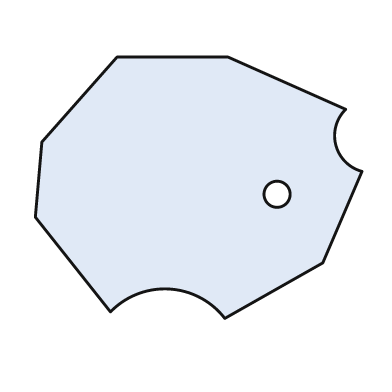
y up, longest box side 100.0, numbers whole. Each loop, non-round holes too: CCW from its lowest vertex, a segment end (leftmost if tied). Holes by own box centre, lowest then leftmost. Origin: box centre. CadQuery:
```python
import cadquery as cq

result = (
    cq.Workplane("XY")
    .moveTo(8.0, -40.0)
    .lineTo(38.0, -23.0)
    .lineTo(50.0, 5.0)
    .threePointArc((42.0, 13.0), (45.0, 24.0))
    .lineTo(9.0, 40.0)
    .lineTo(-25.0, 40.0)
    .lineTo(-48.0, 14.0)
    .lineTo(-50.0, -9.0)
    .lineTo(-27.0, -38.0)
    .threePointArc((-9.0, -31.0), (8.0, -40.0))
    .close()
    .moveTo(24.0, -2.0)
    .circle(4.0)
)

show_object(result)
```